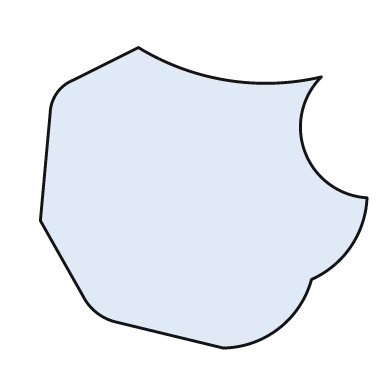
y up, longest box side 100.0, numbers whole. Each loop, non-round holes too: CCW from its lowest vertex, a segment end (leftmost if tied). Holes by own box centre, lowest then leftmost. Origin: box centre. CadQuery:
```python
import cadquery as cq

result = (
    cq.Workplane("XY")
    .moveTo(6.0, -46.0)
    .threePointArc((23.0, -40.0), (33.0, -25.0))
    .threePointArc((45.0, -15.0), (50.0, 0.0))
    .threePointArc((31.0, 14.0), (36.0, 37.0))
    .threePointArc((7.0, 36.0), (-20.0, 46.0))
    .lineTo(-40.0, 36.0)
    .threePointArc((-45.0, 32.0), (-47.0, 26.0))
    .lineTo(-50.0, -7.0)
    .lineTo(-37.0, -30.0)
    .threePointArc((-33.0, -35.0), (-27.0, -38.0))
    .close()
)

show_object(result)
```